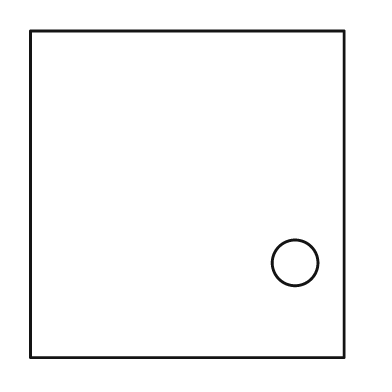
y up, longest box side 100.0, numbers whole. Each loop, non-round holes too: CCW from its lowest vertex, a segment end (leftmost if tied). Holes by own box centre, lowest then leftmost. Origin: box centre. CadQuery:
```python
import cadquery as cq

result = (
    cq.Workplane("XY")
    .moveTo(-48.0, -50.0)
    .lineTo(48.0, -50.0)
    .lineTo(48.0, 50.0)
    .lineTo(-48.0, 50.0)
    .close()
    .moveTo(33.0, -21.0)
    .circle(7.0)
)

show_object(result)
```